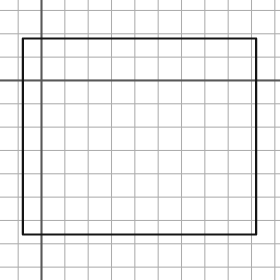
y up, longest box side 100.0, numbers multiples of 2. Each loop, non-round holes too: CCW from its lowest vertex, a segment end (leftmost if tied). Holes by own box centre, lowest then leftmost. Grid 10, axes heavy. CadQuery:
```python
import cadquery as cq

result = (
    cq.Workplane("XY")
    .moveTo(-8.0, -66.0)
    .lineTo(92.0, -66.0)
    .lineTo(92.0, 18.0)
    .lineTo(-8.0, 18.0)
    .close()
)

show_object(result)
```